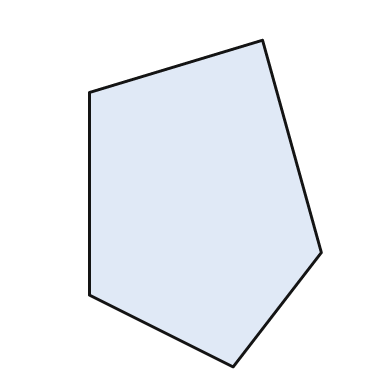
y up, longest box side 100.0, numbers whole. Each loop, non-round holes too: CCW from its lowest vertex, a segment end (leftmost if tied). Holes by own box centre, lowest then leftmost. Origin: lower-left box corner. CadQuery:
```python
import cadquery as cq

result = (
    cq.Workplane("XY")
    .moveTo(44.0, 0.0)
    .lineTo(71.0, 35.0)
    .lineTo(53.0, 100.0)
    .lineTo(0.0, 84.0)
    .lineTo(0.0, 22.0)
    .close()
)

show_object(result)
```